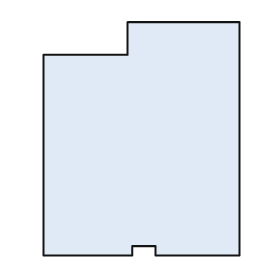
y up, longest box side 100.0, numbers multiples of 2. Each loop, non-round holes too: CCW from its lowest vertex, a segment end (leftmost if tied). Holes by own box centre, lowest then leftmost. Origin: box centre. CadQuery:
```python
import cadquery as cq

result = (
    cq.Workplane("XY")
    .moveTo(-42.0, -50.0)
    .lineTo(-4.0, -50.0)
    .lineTo(-4.0, -46.0)
    .lineTo(6.0, -46.0)
    .lineTo(6.0, -50.0)
    .lineTo(42.0, -50.0)
    .lineTo(42.0, 50.0)
    .lineTo(-6.0, 50.0)
    .lineTo(-6.0, 36.0)
    .lineTo(-42.0, 36.0)
    .close()
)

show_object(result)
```